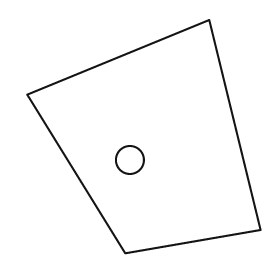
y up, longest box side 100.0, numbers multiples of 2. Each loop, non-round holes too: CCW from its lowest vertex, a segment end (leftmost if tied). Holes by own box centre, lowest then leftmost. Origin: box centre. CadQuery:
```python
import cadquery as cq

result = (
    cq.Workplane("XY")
    .moveTo(-8.0, -50.0)
    .lineTo(50.0, -40.0)
    .lineTo(28.0, 50.0)
    .lineTo(-50.0, 18.0)
    .close()
    .moveTo(-6.0, -10.0)
    .circle(6.0)
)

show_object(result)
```